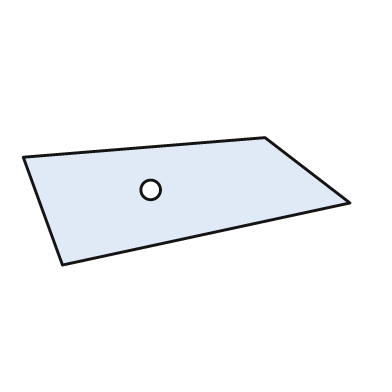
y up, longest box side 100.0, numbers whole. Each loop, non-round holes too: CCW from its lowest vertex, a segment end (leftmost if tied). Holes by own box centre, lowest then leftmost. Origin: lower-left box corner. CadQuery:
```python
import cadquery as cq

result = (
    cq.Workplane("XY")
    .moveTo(12.0, 0.0)
    .lineTo(100.0, 19.0)
    .lineTo(74.0, 39.0)
    .lineTo(0.0, 33.0)
    .close()
    .moveTo(39.0, 23.0)
    .circle(3.0)
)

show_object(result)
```